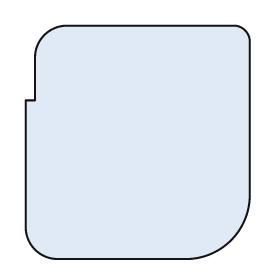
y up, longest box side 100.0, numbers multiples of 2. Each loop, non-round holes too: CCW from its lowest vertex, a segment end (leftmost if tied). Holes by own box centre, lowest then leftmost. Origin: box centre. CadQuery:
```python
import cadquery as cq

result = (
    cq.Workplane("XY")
    .moveTo(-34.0, -50.0)
    .lineTo(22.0, -50.0)
    .threePointArc((40.0, -42.0), (48.0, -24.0))
    .lineTo(48.0, 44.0)
    .threePointArc((46.0, 48.0), (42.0, 50.0))
    .lineTo(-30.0, 50.0)
    .threePointArc((-40.0, 46.0), (-44.0, 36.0))
    .lineTo(-44.0, 18.0)
    .lineTo(-48.0, 18.0)
    .lineTo(-48.0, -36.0)
    .threePointArc((-44.0, -46.0), (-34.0, -50.0))
    .close()
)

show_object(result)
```